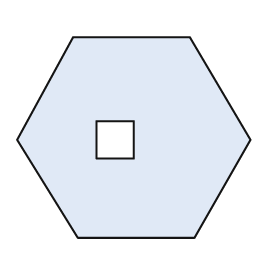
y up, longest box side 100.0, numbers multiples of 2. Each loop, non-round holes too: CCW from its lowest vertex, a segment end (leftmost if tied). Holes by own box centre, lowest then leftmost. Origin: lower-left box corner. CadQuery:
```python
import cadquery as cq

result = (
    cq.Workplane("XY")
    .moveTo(26.0, 0.0)
    .lineTo(76.0, 0.0)
    .lineTo(100.0, 42.0)
    .lineTo(74.0, 86.0)
    .lineTo(24.0, 86.0)
    .lineTo(0.0, 42.0)
    .close()
    .moveTo(34.0, 34.0)
    .lineTo(50.0, 34.0)
    .lineTo(50.0, 50.0)
    .lineTo(34.0, 50.0)
    .close()
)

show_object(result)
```